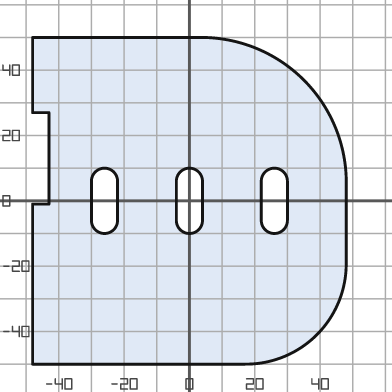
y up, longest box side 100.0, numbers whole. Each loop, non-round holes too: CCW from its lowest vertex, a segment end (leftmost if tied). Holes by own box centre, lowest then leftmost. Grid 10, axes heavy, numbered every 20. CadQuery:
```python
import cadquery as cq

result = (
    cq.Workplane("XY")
    .moveTo(-48.0, -50.0)
    .lineTo(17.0, -50.0)
    .threePointArc((39.0, -41.0), (48.0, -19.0))
    .lineTo(48.0, 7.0)
    .threePointArc((35.0, 37.0), (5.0, 50.0))
    .lineTo(-48.0, 50.0)
    .lineTo(-48.0, 27.0)
    .lineTo(-43.0, 27.0)
    .lineTo(-43.0, -1.0)
    .lineTo(-48.0, -1.0)
    .close()
    .moveTo(-30.0, -6.0)
    .threePointArc((-26.0, -10.0), (-22.0, -6.0))
    .lineTo(-22.0, 6.0)
    .threePointArc((-26.0, 10.0), (-30.0, 6.0))
    .close()
    .moveTo(-4.0, -6.0)
    .threePointArc((0.0, -10.0), (4.0, -6.0))
    .lineTo(4.0, 6.0)
    .threePointArc((0.0, 10.0), (-4.0, 6.0))
    .close()
    .moveTo(22.0, -6.0)
    .threePointArc((26.0, -10.0), (30.0, -6.0))
    .lineTo(30.0, 6.0)
    .threePointArc((26.0, 10.0), (22.0, 6.0))
    .close()
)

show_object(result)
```